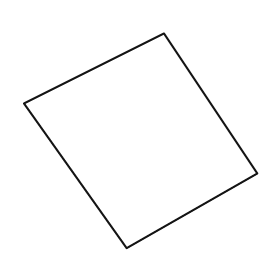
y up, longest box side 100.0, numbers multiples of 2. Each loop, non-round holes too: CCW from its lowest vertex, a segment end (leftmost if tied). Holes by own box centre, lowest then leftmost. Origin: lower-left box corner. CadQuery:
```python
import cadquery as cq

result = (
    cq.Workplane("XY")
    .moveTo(44.0, 0.0)
    .lineTo(100.0, 32.0)
    .lineTo(60.0, 92.0)
    .lineTo(0.0, 62.0)
    .close()
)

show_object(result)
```